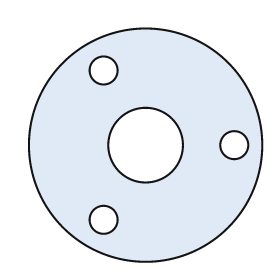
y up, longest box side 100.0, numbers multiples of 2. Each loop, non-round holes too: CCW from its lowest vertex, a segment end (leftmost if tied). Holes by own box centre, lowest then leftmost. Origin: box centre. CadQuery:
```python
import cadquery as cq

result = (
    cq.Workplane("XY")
    .moveTo(0.0, 0.0)
    .circle(50.0)
    .moveTo(-18.0, -32.0)
    .circle(6.0)
    .moveTo(0.0, 0.0)
    .circle(16.0)
    .moveTo(38.0, 0.0)
    .circle(6.0)
    .moveTo(-18.0, 32.0)
    .circle(6.0)
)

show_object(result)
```